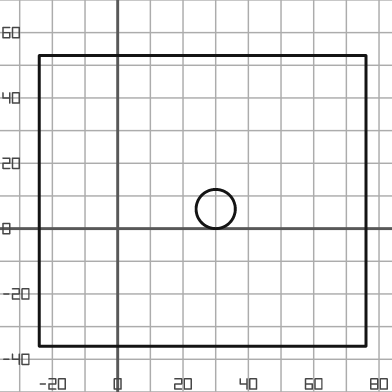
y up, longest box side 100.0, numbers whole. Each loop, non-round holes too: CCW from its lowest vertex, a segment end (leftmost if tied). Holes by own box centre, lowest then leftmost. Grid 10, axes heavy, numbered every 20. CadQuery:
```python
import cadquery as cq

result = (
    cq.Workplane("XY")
    .moveTo(-24.0, -36.0)
    .lineTo(76.0, -36.0)
    .lineTo(76.0, 53.0)
    .lineTo(-24.0, 53.0)
    .close()
    .moveTo(30.0, 6.0)
    .circle(6.0)
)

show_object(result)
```